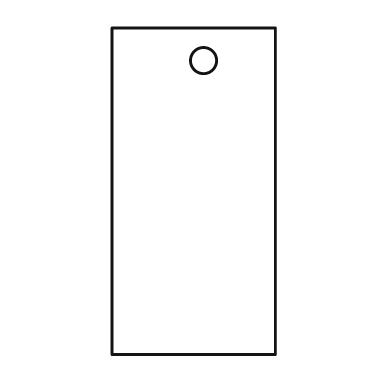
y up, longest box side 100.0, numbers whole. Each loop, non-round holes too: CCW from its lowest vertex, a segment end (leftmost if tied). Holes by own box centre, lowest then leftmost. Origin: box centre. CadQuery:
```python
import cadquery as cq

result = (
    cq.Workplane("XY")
    .moveTo(-25.0, -50.0)
    .lineTo(25.0, -50.0)
    .lineTo(25.0, 50.0)
    .lineTo(-25.0, 50.0)
    .close()
    .moveTo(3.0, 40.0)
    .circle(4.0)
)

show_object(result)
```